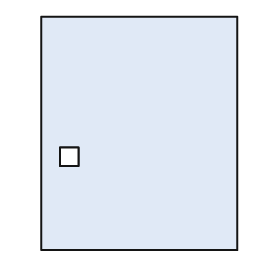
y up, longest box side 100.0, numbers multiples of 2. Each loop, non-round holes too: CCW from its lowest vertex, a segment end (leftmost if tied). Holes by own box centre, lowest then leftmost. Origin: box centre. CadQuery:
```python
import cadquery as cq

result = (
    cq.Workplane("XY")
    .moveTo(-42.0, -50.0)
    .lineTo(42.0, -50.0)
    .lineTo(42.0, 50.0)
    .lineTo(-42.0, 50.0)
    .close()
    .moveTo(-34.0, -14.0)
    .lineTo(-26.0, -14.0)
    .lineTo(-26.0, -6.0)
    .lineTo(-34.0, -6.0)
    .close()
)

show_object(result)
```